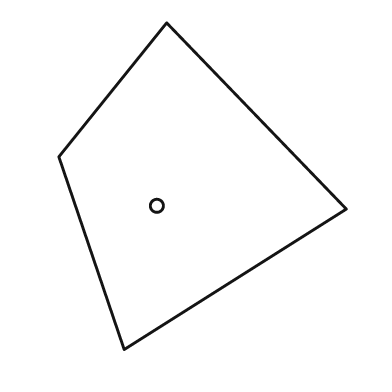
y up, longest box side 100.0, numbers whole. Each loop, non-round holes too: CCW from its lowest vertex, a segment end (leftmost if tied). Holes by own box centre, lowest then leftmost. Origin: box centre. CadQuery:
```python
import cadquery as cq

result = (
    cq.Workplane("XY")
    .moveTo(-24.0, -50.0)
    .lineTo(44.0, -7.0)
    .lineTo(-11.0, 50.0)
    .lineTo(-44.0, 9.0)
    .close()
    .moveTo(-14.0, -6.0)
    .circle(2.0)
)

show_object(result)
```